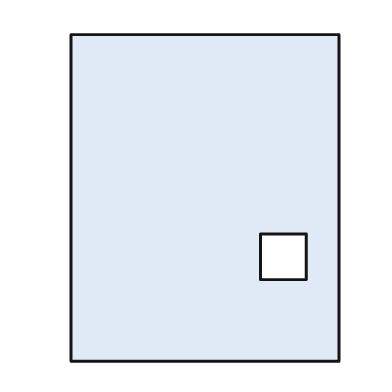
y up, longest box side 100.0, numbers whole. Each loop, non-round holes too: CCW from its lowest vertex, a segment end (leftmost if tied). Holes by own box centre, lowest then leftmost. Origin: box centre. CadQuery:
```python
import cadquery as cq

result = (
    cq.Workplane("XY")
    .moveTo(-41.0, -50.0)
    .lineTo(41.0, -50.0)
    .lineTo(41.0, 50.0)
    .lineTo(-41.0, 50.0)
    .close()
    .moveTo(17.0, -25.0)
    .lineTo(31.0, -25.0)
    .lineTo(31.0, -11.0)
    .lineTo(17.0, -11.0)
    .close()
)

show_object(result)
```